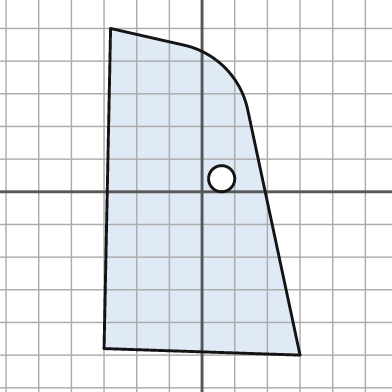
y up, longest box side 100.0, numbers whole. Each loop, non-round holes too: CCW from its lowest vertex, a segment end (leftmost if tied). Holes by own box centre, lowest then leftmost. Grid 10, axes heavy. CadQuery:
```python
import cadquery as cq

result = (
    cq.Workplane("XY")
    .moveTo(30.0, -50.0)
    .lineTo(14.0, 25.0)
    .threePointArc((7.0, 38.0), (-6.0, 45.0))
    .lineTo(-28.0, 50.0)
    .lineTo(-30.0, -48.0)
    .close()
    .moveTo(6.0, 4.0)
    .circle(4.0)
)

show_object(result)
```